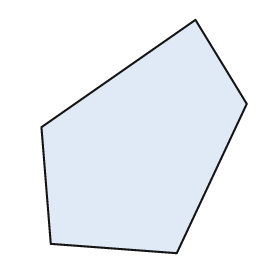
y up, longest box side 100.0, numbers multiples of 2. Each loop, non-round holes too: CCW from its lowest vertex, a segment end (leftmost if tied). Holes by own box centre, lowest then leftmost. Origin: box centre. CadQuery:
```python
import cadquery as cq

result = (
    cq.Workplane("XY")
    .moveTo(14.0, -50.0)
    .lineTo(44.0, 14.0)
    .lineTo(22.0, 50.0)
    .lineTo(-44.0, 4.0)
    .lineTo(-40.0, -46.0)
    .close()
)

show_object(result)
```